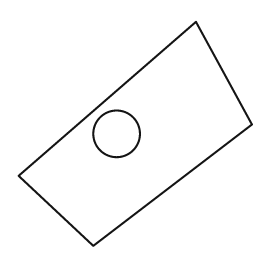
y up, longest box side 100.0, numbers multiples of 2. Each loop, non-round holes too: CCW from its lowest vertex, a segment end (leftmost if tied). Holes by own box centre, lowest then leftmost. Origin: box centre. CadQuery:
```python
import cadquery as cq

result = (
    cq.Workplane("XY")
    .moveTo(-18.0, -48.0)
    .lineTo(50.0, 4.0)
    .lineTo(26.0, 48.0)
    .lineTo(-50.0, -18.0)
    .close()
    .moveTo(-8.0, 0.0)
    .circle(10.0)
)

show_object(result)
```